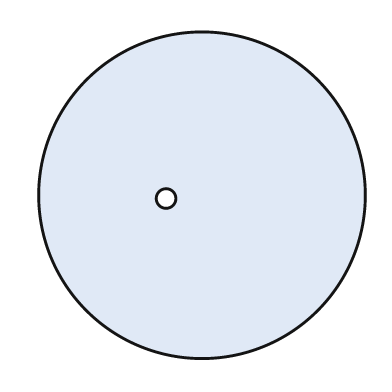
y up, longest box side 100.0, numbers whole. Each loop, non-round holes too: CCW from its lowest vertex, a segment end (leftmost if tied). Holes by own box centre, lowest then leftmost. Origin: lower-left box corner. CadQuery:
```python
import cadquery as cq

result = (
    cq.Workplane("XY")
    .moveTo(50.0, 50.0)
    .circle(50.0)
    .moveTo(39.0, 49.0)
    .circle(3.0)
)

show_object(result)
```